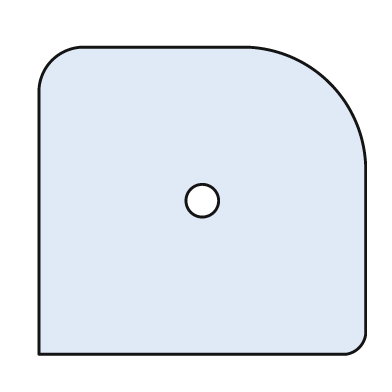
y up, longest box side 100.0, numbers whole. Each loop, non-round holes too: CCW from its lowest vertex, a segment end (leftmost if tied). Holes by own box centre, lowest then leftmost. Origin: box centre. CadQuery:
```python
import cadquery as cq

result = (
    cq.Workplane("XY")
    .moveTo(-50.0, -47.0)
    .lineTo(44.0, -47.0)
    .threePointArc((48.0, -45.0), (50.0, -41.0))
    .lineTo(50.0, 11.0)
    .threePointArc((39.0, 36.0), (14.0, 47.0))
    .lineTo(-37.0, 47.0)
    .threePointArc((-46.0, 43.0), (-50.0, 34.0))
    .close()
    .moveTo(0.0, 0.0)
    .circle(5.0)
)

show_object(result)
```